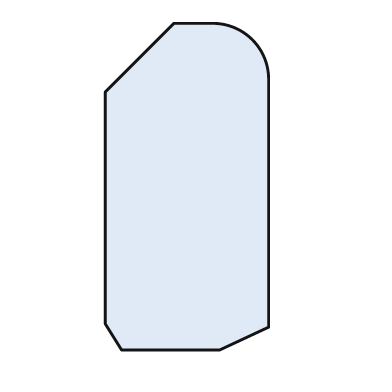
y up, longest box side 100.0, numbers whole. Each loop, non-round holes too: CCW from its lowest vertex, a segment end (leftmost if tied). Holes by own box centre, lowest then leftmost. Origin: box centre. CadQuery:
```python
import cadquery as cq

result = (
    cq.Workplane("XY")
    .moveTo(-20.0, -50.0)
    .lineTo(10.0, -50.0)
    .lineTo(25.0, -43.0)
    .lineTo(25.0, 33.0)
    .threePointArc((20.0, 45.0), (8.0, 50.0))
    .lineTo(-4.0, 50.0)
    .lineTo(-25.0, 29.0)
    .lineTo(-25.0, -42.0)
    .close()
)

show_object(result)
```